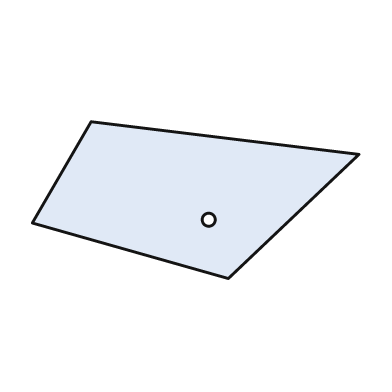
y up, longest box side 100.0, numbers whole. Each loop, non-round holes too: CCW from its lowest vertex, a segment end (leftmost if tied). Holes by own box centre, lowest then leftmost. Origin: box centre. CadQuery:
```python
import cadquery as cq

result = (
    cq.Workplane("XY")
    .moveTo(10.0, -24.0)
    .lineTo(50.0, 14.0)
    .lineTo(-32.0, 24.0)
    .lineTo(-50.0, -7.0)
    .close()
    .moveTo(4.0, -6.0)
    .circle(2.0)
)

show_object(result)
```